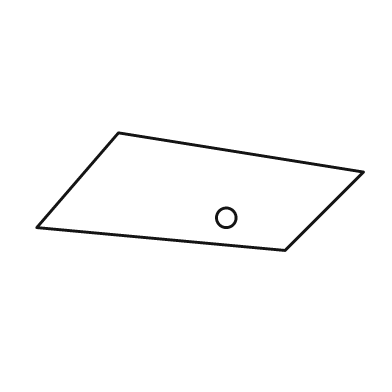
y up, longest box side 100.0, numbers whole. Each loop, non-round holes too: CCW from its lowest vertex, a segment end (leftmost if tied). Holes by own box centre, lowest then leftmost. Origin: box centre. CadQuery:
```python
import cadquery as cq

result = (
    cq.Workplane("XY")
    .moveTo(26.0, -18.0)
    .lineTo(50.0, 6.0)
    .lineTo(-25.0, 18.0)
    .lineTo(-50.0, -11.0)
    .close()
    .moveTo(8.0, -8.0)
    .circle(3.0)
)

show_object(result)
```